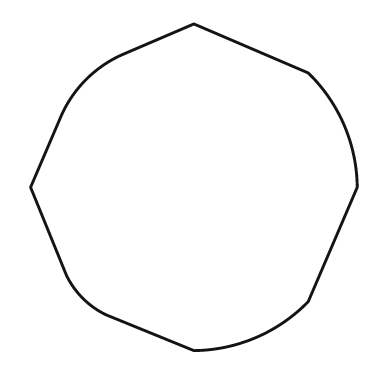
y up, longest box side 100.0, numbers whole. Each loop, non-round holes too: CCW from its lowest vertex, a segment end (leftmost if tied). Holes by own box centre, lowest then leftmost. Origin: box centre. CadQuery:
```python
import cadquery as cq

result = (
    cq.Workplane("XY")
    .moveTo(0.0, -50.0)
    .threePointArc((19.0, -46.0), (35.0, -35.0))
    .lineTo(50.0, 0.0)
    .threePointArc((46.0, 19.0), (35.0, 35.0))
    .lineTo(0.0, 50.0)
    .lineTo(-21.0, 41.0)
    .threePointArc((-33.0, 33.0), (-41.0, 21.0))
    .lineTo(-50.0, 0.0)
    .lineTo(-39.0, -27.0)
    .threePointArc((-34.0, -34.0), (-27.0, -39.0))
    .close()
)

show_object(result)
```